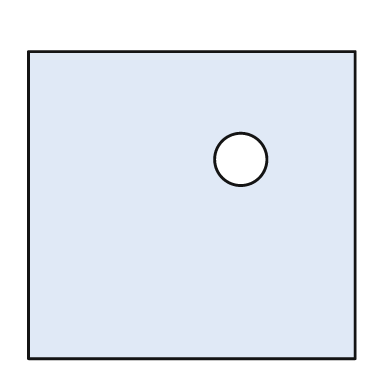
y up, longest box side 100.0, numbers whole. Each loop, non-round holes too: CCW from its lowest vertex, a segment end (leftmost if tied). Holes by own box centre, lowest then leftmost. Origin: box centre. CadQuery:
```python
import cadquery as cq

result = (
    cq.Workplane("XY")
    .moveTo(-50.0, -47.0)
    .lineTo(50.0, -47.0)
    .lineTo(50.0, 47.0)
    .lineTo(-50.0, 47.0)
    .close()
    .moveTo(15.0, 14.0)
    .circle(8.0)
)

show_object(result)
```